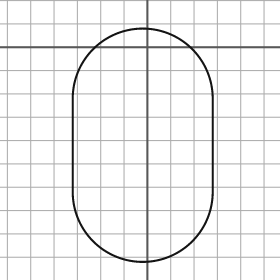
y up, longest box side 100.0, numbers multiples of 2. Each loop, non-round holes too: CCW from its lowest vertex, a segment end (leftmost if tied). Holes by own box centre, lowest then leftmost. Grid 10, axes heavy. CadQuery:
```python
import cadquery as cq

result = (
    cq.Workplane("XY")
    .moveTo(-32.0, -62.0)
    .threePointArc((-2.0, -92.0), (28.0, -62.0))
    .lineTo(28.0, -22.0)
    .threePointArc((-2.0, 8.0), (-32.0, -22.0))
    .close()
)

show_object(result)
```